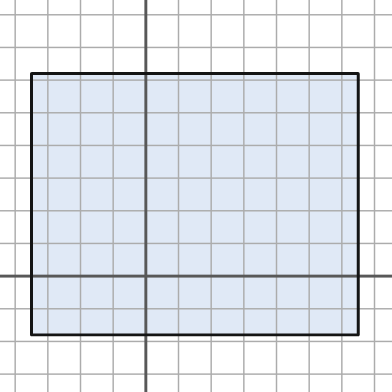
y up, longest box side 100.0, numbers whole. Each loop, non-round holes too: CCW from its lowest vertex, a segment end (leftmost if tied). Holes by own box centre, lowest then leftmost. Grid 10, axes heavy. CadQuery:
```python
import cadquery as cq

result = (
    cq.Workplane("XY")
    .moveTo(-35.0, -18.0)
    .lineTo(65.0, -18.0)
    .lineTo(65.0, 62.0)
    .lineTo(-35.0, 62.0)
    .close()
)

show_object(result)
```